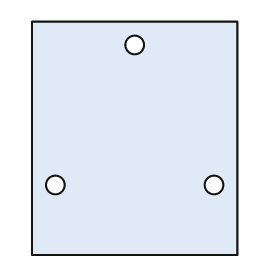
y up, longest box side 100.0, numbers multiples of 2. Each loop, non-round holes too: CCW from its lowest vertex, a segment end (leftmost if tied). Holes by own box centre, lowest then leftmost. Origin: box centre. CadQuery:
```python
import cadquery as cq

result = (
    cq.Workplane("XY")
    .moveTo(-44.0, -50.0)
    .lineTo(44.0, -50.0)
    .lineTo(44.0, 50.0)
    .lineTo(-44.0, 50.0)
    .close()
    .moveTo(-34.0, -20.0)
    .circle(4.0)
    .moveTo(34.0, -20.0)
    .circle(4.0)
    .moveTo(0.0, 40.0)
    .circle(4.0)
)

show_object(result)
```